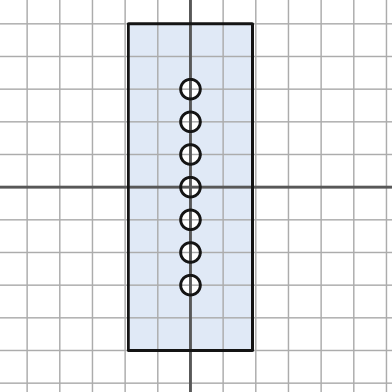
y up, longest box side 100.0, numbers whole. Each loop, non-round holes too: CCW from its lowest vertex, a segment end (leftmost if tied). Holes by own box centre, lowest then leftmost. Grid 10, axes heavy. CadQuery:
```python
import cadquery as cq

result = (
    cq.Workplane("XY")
    .moveTo(-19.0, -50.0)
    .lineTo(19.0, -50.0)
    .lineTo(19.0, 50.0)
    .lineTo(-19.0, 50.0)
    .close()
    .moveTo(0.0, -30.0)
    .circle(3.0)
    .moveTo(0.0, -20.0)
    .circle(3.0)
    .moveTo(0.0, -10.0)
    .circle(3.0)
    .moveTo(0.0, 0.0)
    .circle(3.0)
    .moveTo(0.0, 10.0)
    .circle(3.0)
    .moveTo(0.0, 20.0)
    .circle(3.0)
    .moveTo(0.0, 30.0)
    .circle(3.0)
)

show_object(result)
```